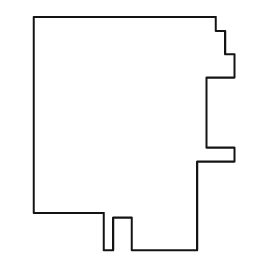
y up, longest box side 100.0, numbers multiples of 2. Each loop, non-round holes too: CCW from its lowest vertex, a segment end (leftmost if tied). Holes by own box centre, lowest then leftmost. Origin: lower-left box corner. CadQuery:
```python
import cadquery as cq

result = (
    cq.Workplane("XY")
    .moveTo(30.0, 0.0)
    .lineTo(34.0, 0.0)
    .lineTo(34.0, 14.0)
    .lineTo(42.0, 14.0)
    .lineTo(42.0, 0.0)
    .lineTo(70.0, 0.0)
    .lineTo(70.0, 38.0)
    .lineTo(86.0, 38.0)
    .lineTo(86.0, 44.0)
    .lineTo(74.0, 44.0)
    .lineTo(74.0, 74.0)
    .lineTo(86.0, 74.0)
    .lineTo(86.0, 84.0)
    .lineTo(82.0, 84.0)
    .lineTo(82.0, 94.0)
    .lineTo(78.0, 94.0)
    .lineTo(78.0, 100.0)
    .lineTo(0.0, 100.0)
    .lineTo(0.0, 16.0)
    .lineTo(30.0, 16.0)
    .close()
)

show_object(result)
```